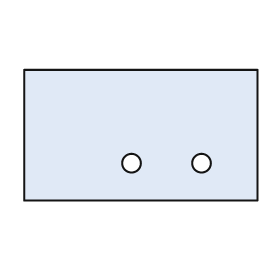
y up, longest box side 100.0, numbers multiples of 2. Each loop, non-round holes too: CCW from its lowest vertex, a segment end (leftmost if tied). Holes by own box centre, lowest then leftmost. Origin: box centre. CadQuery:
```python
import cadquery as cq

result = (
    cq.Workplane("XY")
    .moveTo(-50.0, -28.0)
    .lineTo(50.0, -28.0)
    .lineTo(50.0, 28.0)
    .lineTo(-50.0, 28.0)
    .close()
    .moveTo(-4.0, -12.0)
    .circle(4.0)
    .moveTo(26.0, -12.0)
    .circle(4.0)
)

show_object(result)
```